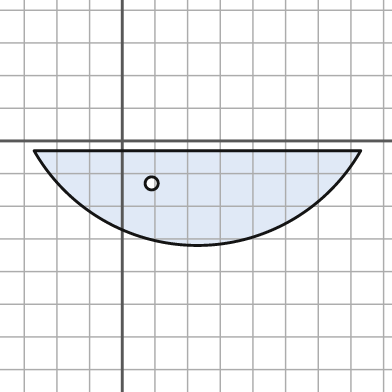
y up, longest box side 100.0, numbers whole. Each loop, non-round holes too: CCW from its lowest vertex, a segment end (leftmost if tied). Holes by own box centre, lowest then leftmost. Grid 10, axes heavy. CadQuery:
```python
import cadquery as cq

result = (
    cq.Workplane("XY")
    .moveTo(-27.0, -3.0)
    .threePointArc((23.0, -32.0), (73.0, -3.0))
    .close()
    .moveTo(9.0, -13.0)
    .circle(2.0)
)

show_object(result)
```